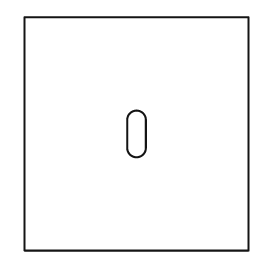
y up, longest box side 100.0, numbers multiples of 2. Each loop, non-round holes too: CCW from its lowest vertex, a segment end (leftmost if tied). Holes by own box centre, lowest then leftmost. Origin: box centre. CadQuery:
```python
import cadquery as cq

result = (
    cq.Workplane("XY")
    .moveTo(-48.0, -50.0)
    .lineTo(48.0, -50.0)
    .lineTo(48.0, 50.0)
    .lineTo(-48.0, 50.0)
    .close()
    .moveTo(-4.0, -6.0)
    .threePointArc((0.0, -10.0), (4.0, -6.0))
    .lineTo(4.0, 6.0)
    .threePointArc((0.0, 10.0), (-4.0, 6.0))
    .close()
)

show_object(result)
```